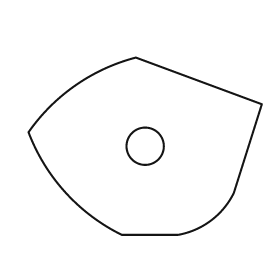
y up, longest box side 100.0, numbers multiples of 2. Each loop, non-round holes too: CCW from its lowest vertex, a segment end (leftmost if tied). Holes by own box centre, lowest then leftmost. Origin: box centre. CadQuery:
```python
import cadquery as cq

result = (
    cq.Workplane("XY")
    .moveTo(-10.0, -38.0)
    .lineTo(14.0, -38.0)
    .threePointArc((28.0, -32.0), (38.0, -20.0))
    .lineTo(50.0, 18.0)
    .lineTo(-4.0, 38.0)
    .threePointArc((-30.0, 26.0), (-50.0, 6.0))
    .threePointArc((-34.0, -20.0), (-10.0, -38.0))
    .close()
    .moveTo(0.0, 0.0)
    .circle(8.0)
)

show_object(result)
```